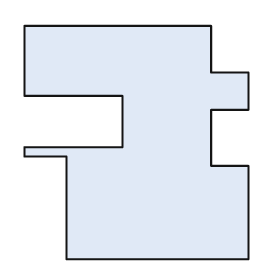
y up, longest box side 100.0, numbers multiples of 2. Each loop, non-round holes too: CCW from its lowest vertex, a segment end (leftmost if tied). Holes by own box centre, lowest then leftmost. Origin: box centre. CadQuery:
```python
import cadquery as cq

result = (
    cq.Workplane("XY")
    .moveTo(-30.0, -50.0)
    .lineTo(48.0, -50.0)
    .lineTo(48.0, -10.0)
    .lineTo(32.0, -10.0)
    .lineTo(32.0, 14.0)
    .lineTo(48.0, 14.0)
    .lineTo(48.0, 30.0)
    .lineTo(32.0, 30.0)
    .lineTo(32.0, 50.0)
    .lineTo(-48.0, 50.0)
    .lineTo(-48.0, 20.0)
    .lineTo(-6.0, 20.0)
    .lineTo(-6.0, -2.0)
    .lineTo(-48.0, -2.0)
    .lineTo(-48.0, -6.0)
    .lineTo(-30.0, -6.0)
    .close()
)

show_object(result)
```